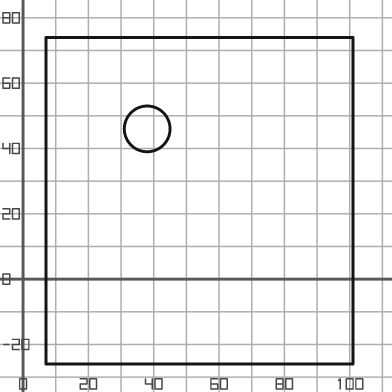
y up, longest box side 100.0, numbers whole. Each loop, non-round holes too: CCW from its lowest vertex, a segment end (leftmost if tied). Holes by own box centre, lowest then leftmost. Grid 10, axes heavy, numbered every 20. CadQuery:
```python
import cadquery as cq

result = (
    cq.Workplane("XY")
    .moveTo(7.0, -26.0)
    .lineTo(101.0, -26.0)
    .lineTo(101.0, 74.0)
    .lineTo(7.0, 74.0)
    .close()
    .moveTo(38.0, 46.0)
    .circle(7.0)
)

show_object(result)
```